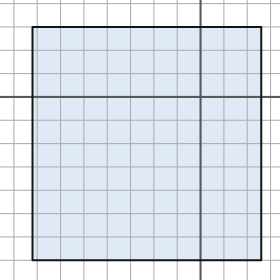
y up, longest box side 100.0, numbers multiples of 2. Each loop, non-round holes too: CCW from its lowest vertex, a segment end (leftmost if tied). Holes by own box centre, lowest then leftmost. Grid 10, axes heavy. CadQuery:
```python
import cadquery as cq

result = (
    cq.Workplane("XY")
    .moveTo(-72.0, -70.0)
    .lineTo(26.0, -70.0)
    .lineTo(26.0, 30.0)
    .lineTo(-72.0, 30.0)
    .close()
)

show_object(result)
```